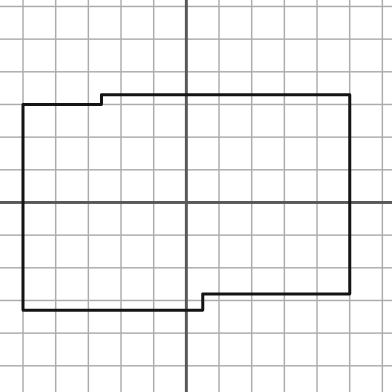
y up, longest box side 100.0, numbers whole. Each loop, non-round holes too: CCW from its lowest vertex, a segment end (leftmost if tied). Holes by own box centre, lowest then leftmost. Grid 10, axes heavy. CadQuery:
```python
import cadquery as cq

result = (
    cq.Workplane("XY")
    .moveTo(-50.0, -33.0)
    .lineTo(5.0, -33.0)
    .lineTo(5.0, -28.0)
    .lineTo(50.0, -28.0)
    .lineTo(50.0, 33.0)
    .lineTo(-26.0, 33.0)
    .lineTo(-26.0, 30.0)
    .lineTo(-50.0, 30.0)
    .close()
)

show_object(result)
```